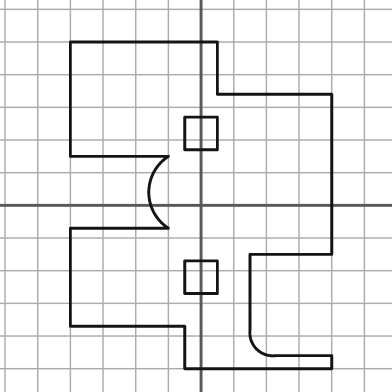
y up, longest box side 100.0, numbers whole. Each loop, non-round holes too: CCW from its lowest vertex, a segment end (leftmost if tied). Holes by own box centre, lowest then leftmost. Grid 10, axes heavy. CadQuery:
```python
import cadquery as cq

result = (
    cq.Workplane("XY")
    .moveTo(-5.0, -50.0)
    .lineTo(40.0, -50.0)
    .lineTo(40.0, -46.0)
    .lineTo(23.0, -46.0)
    .threePointArc((17.0, -44.0), (15.0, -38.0))
    .lineTo(15.0, -15.0)
    .lineTo(40.0, -15.0)
    .lineTo(40.0, 34.0)
    .lineTo(5.0, 34.0)
    .lineTo(5.0, 50.0)
    .lineTo(-40.0, 50.0)
    .lineTo(-40.0, 15.0)
    .lineTo(-10.0, 15.0)
    .threePointArc((-16.0, 4.0), (-10.0, -7.0))
    .lineTo(-40.0, -7.0)
    .lineTo(-40.0, -37.0)
    .lineTo(-5.0, -37.0)
    .close()
    .moveTo(-5.0, -27.0)
    .lineTo(5.0, -27.0)
    .lineTo(5.0, -17.0)
    .lineTo(-5.0, -17.0)
    .close()
    .moveTo(-5.0, 17.0)
    .lineTo(5.0, 17.0)
    .lineTo(5.0, 27.0)
    .lineTo(-5.0, 27.0)
    .close()
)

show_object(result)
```